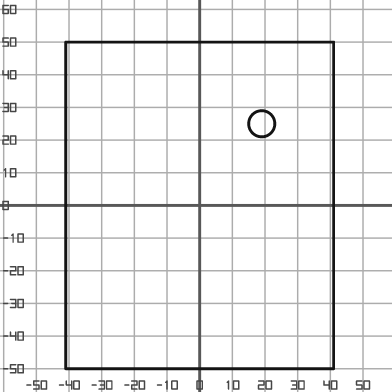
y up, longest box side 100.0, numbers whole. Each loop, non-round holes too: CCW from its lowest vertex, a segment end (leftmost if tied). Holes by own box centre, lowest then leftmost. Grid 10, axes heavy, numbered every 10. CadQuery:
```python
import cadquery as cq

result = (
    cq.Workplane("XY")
    .moveTo(-41.0, -50.0)
    .lineTo(41.0, -50.0)
    .lineTo(41.0, 50.0)
    .lineTo(-41.0, 50.0)
    .close()
    .moveTo(19.0, 25.0)
    .circle(4.0)
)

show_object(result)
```